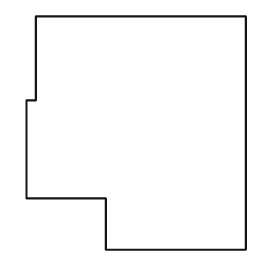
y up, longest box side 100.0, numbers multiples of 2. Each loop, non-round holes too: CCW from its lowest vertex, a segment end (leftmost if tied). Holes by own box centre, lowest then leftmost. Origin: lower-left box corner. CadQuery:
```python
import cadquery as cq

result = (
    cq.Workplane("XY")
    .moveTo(34.0, 0.0)
    .lineTo(94.0, 0.0)
    .lineTo(94.0, 100.0)
    .lineTo(4.0, 100.0)
    .lineTo(4.0, 64.0)
    .lineTo(0.0, 64.0)
    .lineTo(0.0, 22.0)
    .lineTo(34.0, 22.0)
    .close()
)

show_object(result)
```